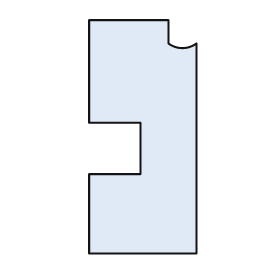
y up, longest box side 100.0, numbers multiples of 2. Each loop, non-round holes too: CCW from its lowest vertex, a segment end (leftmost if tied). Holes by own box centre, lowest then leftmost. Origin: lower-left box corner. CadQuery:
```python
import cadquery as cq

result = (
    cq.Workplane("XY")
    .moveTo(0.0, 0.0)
    .lineTo(46.0, 0.0)
    .lineTo(46.0, 90.0)
    .threePointArc((40.0, 88.0), (34.0, 90.0))
    .lineTo(34.0, 100.0)
    .lineTo(0.0, 100.0)
    .lineTo(0.0, 56.0)
    .lineTo(22.0, 56.0)
    .lineTo(22.0, 34.0)
    .lineTo(0.0, 34.0)
    .close()
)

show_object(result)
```